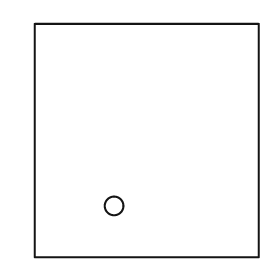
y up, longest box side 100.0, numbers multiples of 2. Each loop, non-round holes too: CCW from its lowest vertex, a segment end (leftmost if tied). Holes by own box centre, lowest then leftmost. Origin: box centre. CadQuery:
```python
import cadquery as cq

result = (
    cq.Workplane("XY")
    .moveTo(-48.0, -50.0)
    .lineTo(48.0, -50.0)
    .lineTo(48.0, 50.0)
    .lineTo(-48.0, 50.0)
    .close()
    .moveTo(-14.0, -28.0)
    .circle(4.0)
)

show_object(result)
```